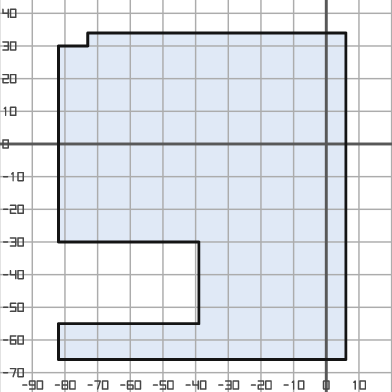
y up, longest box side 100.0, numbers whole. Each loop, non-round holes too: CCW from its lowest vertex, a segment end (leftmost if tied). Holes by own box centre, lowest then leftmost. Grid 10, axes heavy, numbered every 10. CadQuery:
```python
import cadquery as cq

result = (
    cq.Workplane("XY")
    .moveTo(-82.0, -66.0)
    .lineTo(6.0, -66.0)
    .lineTo(6.0, 34.0)
    .lineTo(-73.0, 34.0)
    .lineTo(-73.0, 30.0)
    .lineTo(-82.0, 30.0)
    .lineTo(-82.0, -30.0)
    .lineTo(-39.0, -30.0)
    .lineTo(-39.0, -55.0)
    .lineTo(-82.0, -55.0)
    .close()
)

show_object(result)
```